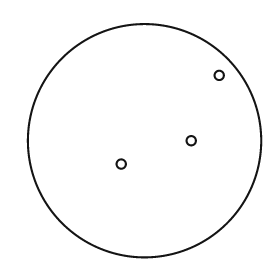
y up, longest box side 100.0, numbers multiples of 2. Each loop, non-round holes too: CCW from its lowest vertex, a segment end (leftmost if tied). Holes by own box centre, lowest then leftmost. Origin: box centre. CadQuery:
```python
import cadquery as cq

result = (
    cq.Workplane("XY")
    .moveTo(0.0, 0.0)
    .circle(50.0)
    .moveTo(-10.0, -10.0)
    .circle(2.0)
    .moveTo(20.0, 0.0)
    .circle(2.0)
    .moveTo(32.0, 28.0)
    .circle(2.0)
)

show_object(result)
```